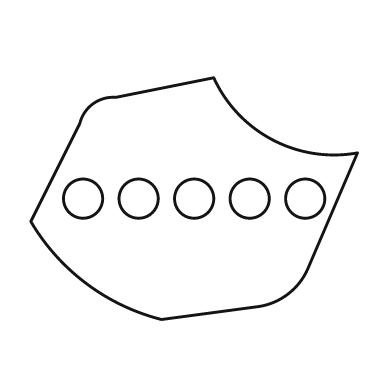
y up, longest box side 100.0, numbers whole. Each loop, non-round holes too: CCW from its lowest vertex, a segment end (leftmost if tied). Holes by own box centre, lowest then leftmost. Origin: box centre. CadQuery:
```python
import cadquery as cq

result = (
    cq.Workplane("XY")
    .moveTo(-10.0, -37.0)
    .lineTo(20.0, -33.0)
    .threePointArc((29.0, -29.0), (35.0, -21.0))
    .lineTo(50.0, 14.0)
    .threePointArc((24.0, 18.0), (6.0, 37.0))
    .lineTo(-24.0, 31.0)
    .threePointArc((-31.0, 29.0), (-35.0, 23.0))
    .lineTo(-50.0, -7.0)
    .threePointArc((-33.0, -26.0), (-10.0, -37.0))
    .close()
    .moveTo(-34.0, 0.0)
    .circle(6.0)
    .moveTo(-17.0, 0.0)
    .circle(6.0)
    .moveTo(0.0, 0.0)
    .circle(6.0)
    .moveTo(17.0, 0.0)
    .circle(6.0)
    .moveTo(34.0, 0.0)
    .circle(6.0)
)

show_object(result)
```